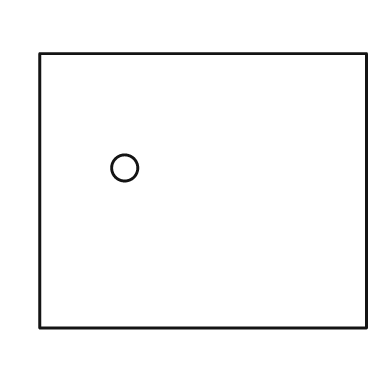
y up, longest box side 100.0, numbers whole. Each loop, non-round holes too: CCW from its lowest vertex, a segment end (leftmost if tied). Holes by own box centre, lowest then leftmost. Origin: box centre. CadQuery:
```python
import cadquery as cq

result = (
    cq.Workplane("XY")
    .moveTo(-50.0, -42.0)
    .lineTo(50.0, -42.0)
    .lineTo(50.0, 42.0)
    .lineTo(-50.0, 42.0)
    .close()
    .moveTo(-24.0, 7.0)
    .circle(4.0)
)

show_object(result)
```